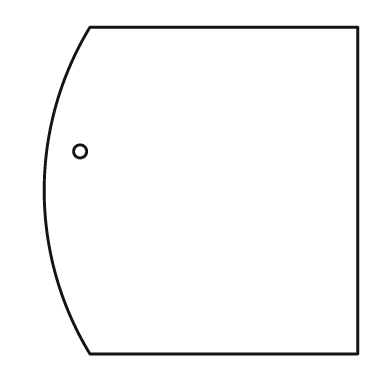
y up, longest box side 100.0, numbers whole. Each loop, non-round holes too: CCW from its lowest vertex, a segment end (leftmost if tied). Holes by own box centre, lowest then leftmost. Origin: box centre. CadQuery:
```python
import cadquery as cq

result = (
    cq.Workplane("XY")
    .moveTo(-34.0, -50.0)
    .lineTo(48.0, -50.0)
    .lineTo(48.0, 50.0)
    .lineTo(-34.0, 50.0)
    .threePointArc((-48.0, 0.0), (-34.0, -50.0))
    .close()
    .moveTo(-37.0, 12.0)
    .circle(2.0)
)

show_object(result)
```